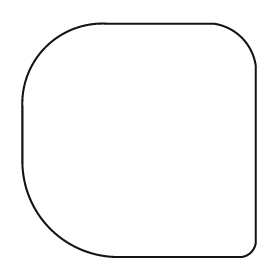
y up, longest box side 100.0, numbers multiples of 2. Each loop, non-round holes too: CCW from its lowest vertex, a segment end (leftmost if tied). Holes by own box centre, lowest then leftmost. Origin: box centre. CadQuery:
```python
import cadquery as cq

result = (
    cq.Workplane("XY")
    .moveTo(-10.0, -50.0)
    .lineTo(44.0, -50.0)
    .threePointArc((48.0, -48.0), (50.0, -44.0))
    .lineTo(50.0, 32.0)
    .threePointArc((44.0, 44.0), (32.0, 50.0))
    .lineTo(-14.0, 50.0)
    .threePointArc((-40.0, 40.0), (-50.0, 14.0))
    .lineTo(-50.0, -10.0)
    .threePointArc((-38.0, -38.0), (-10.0, -50.0))
    .close()
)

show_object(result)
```